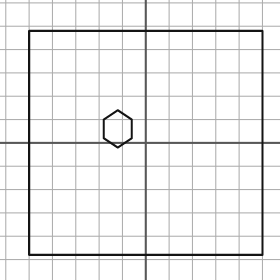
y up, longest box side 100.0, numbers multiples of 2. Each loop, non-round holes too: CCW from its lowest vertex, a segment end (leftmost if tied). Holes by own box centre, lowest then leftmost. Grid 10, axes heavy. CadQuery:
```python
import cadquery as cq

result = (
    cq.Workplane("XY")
    .moveTo(-50.0, -48.0)
    .lineTo(50.0, -48.0)
    .lineTo(50.0, 48.0)
    .lineTo(-50.0, 48.0)
    .close()
    .moveTo(-12.0, -2.0)
    .lineTo(-6.0, 2.0)
    .lineTo(-6.0, 10.0)
    .lineTo(-12.0, 14.0)
    .lineTo(-18.0, 10.0)
    .lineTo(-18.0, 2.0)
    .close()
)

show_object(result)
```